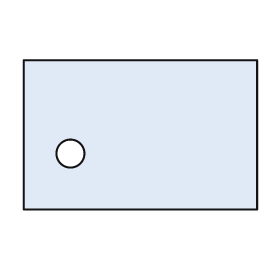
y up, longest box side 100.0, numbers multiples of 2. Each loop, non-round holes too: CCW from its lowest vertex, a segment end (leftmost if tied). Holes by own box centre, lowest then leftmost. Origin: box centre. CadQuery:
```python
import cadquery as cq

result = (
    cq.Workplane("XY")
    .moveTo(-50.0, -32.0)
    .lineTo(50.0, -32.0)
    .lineTo(50.0, 32.0)
    .lineTo(-50.0, 32.0)
    .close()
    .moveTo(-30.0, -8.0)
    .circle(6.0)
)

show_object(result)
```